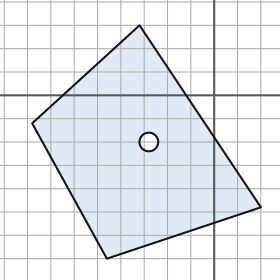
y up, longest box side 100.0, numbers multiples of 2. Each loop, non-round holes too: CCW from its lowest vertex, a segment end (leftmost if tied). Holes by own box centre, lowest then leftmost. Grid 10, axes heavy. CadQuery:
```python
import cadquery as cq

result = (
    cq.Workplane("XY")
    .moveTo(-46.0, -70.0)
    .lineTo(20.0, -48.0)
    .lineTo(-32.0, 30.0)
    .lineTo(-78.0, -12.0)
    .close()
    .moveTo(-28.0, -20.0)
    .circle(4.0)
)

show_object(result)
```